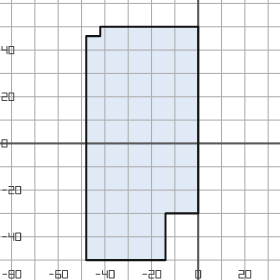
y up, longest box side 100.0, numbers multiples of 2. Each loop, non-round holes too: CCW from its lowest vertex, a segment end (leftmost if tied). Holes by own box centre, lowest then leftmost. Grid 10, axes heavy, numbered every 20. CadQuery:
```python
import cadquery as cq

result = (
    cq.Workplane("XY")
    .moveTo(-48.0, -50.0)
    .lineTo(-14.0, -50.0)
    .lineTo(-14.0, -30.0)
    .lineTo(0.0, -30.0)
    .lineTo(0.0, 50.0)
    .lineTo(-42.0, 50.0)
    .lineTo(-42.0, 46.0)
    .lineTo(-48.0, 46.0)
    .close()
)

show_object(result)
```